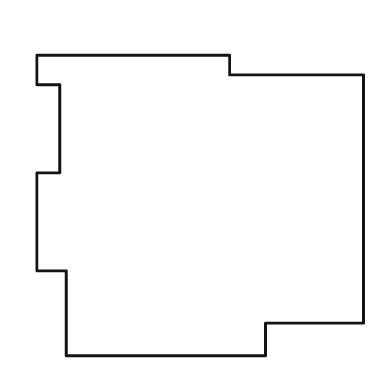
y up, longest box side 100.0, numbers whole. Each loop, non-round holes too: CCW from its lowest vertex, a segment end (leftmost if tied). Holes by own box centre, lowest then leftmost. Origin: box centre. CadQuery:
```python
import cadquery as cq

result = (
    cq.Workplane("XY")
    .moveTo(-41.0, -46.0)
    .lineTo(20.0, -46.0)
    .lineTo(20.0, -36.0)
    .lineTo(50.0, -36.0)
    .lineTo(50.0, 40.0)
    .lineTo(9.0, 40.0)
    .lineTo(9.0, 46.0)
    .lineTo(-50.0, 46.0)
    .lineTo(-50.0, 37.0)
    .lineTo(-43.0, 37.0)
    .lineTo(-43.0, 10.0)
    .lineTo(-50.0, 10.0)
    .lineTo(-50.0, -20.0)
    .lineTo(-41.0, -20.0)
    .close()
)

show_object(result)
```